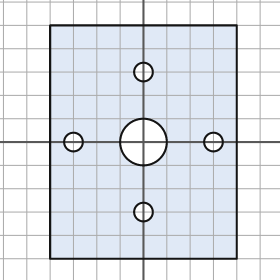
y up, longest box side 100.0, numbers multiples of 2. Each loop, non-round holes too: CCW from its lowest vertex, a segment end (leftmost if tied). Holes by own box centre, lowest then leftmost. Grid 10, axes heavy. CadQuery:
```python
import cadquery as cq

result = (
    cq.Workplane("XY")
    .moveTo(-40.0, -50.0)
    .lineTo(40.0, -50.0)
    .lineTo(40.0, 50.0)
    .lineTo(-40.0, 50.0)
    .close()
    .moveTo(0.0, -30.0)
    .circle(4.0)
    .moveTo(-30.0, 0.0)
    .circle(4.0)
    .moveTo(0.0, 0.0)
    .circle(10.0)
    .moveTo(30.0, 0.0)
    .circle(4.0)
    .moveTo(0.0, 30.0)
    .circle(4.0)
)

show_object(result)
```